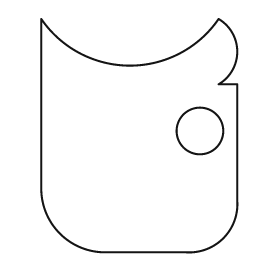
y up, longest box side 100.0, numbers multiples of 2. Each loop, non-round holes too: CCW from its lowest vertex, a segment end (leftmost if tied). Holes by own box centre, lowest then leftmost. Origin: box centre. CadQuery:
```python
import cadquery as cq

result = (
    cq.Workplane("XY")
    .moveTo(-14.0, -50.0)
    .lineTo(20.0, -50.0)
    .threePointArc((36.0, -44.0), (42.0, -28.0))
    .lineTo(42.0, 22.0)
    .lineTo(34.0, 22.0)
    .threePointArc((42.0, 36.0), (34.0, 50.0))
    .threePointArc((-4.0, 30.0), (-42.0, 50.0))
    .lineTo(-42.0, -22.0)
    .threePointArc((-34.0, -42.0), (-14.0, -50.0))
    .close()
    .moveTo(26.0, 2.0)
    .circle(10.0)
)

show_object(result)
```